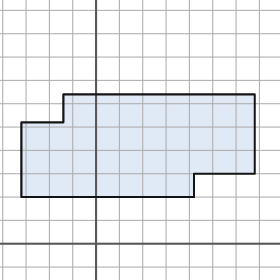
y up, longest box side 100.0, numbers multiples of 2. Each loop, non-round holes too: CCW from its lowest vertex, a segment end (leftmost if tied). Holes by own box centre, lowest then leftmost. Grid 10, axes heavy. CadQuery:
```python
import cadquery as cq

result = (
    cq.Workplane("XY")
    .moveTo(-32.0, 20.0)
    .lineTo(42.0, 20.0)
    .lineTo(42.0, 30.0)
    .lineTo(68.0, 30.0)
    .lineTo(68.0, 64.0)
    .lineTo(-14.0, 64.0)
    .lineTo(-14.0, 52.0)
    .lineTo(-32.0, 52.0)
    .close()
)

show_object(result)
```